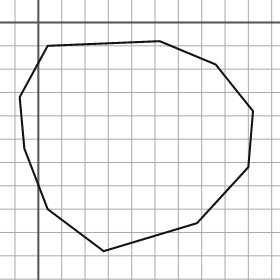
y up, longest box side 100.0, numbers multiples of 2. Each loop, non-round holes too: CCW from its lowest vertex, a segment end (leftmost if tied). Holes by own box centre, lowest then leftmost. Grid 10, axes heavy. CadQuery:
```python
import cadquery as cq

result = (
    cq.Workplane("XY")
    .moveTo(28.0, -98.0)
    .lineTo(68.0, -86.0)
    .lineTo(90.0, -62.0)
    .lineTo(92.0, -38.0)
    .lineTo(76.0, -18.0)
    .lineTo(52.0, -8.0)
    .lineTo(4.0, -10.0)
    .lineTo(-8.0, -32.0)
    .lineTo(-6.0, -54.0)
    .lineTo(4.0, -80.0)
    .close()
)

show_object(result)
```